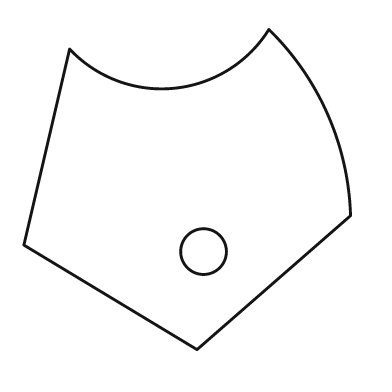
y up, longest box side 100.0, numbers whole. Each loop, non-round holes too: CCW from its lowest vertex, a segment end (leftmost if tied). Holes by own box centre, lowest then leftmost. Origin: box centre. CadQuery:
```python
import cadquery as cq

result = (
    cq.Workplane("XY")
    .moveTo(3.0, -49.0)
    .lineTo(50.0, -8.0)
    .threePointArc((43.0, 23.0), (25.0, 49.0))
    .threePointArc((-4.0, 31.0), (-36.0, 43.0))
    .lineTo(-50.0, -17.0)
    .close()
    .moveTo(5.0, -19.0)
    .circle(7.0)
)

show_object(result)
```